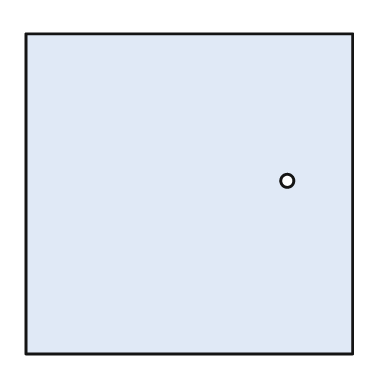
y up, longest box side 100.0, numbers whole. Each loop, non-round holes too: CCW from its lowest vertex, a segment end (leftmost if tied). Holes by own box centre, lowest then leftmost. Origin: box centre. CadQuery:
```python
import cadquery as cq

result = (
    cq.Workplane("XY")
    .moveTo(-50.0, -49.0)
    .lineTo(50.0, -49.0)
    .lineTo(50.0, 49.0)
    .lineTo(-50.0, 49.0)
    .close()
    .moveTo(30.0, 4.0)
    .circle(2.0)
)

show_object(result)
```